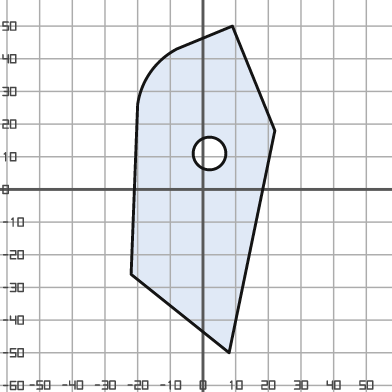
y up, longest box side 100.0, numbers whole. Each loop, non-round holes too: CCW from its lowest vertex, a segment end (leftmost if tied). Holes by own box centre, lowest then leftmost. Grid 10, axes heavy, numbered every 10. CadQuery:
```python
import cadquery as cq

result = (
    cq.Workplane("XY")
    .moveTo(8.0, -50.0)
    .lineTo(22.0, 18.0)
    .lineTo(9.0, 50.0)
    .lineTo(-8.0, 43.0)
    .threePointArc((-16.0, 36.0), (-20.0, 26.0))
    .lineTo(-22.0, -26.0)
    .close()
    .moveTo(2.0, 11.0)
    .circle(5.0)
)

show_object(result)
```